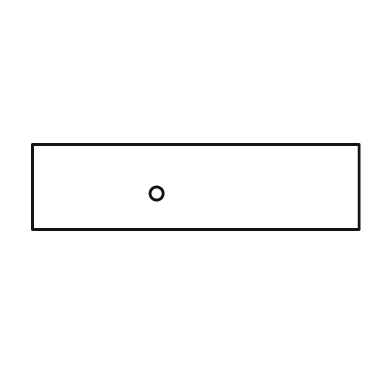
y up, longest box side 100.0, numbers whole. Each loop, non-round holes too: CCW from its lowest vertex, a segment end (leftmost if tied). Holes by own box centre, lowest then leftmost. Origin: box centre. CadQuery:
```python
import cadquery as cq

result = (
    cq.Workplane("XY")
    .moveTo(-50.0, -13.0)
    .lineTo(50.0, -13.0)
    .lineTo(50.0, 13.0)
    .lineTo(-50.0, 13.0)
    .close()
    .moveTo(-12.0, -2.0)
    .circle(2.0)
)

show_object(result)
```